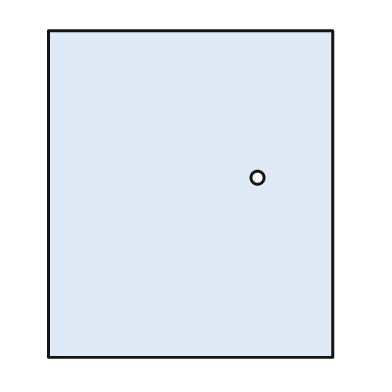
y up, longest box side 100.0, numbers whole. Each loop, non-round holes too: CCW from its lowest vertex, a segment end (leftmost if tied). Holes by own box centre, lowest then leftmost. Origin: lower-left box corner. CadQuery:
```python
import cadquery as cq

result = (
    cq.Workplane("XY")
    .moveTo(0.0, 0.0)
    .lineTo(87.0, 0.0)
    .lineTo(87.0, 100.0)
    .lineTo(0.0, 100.0)
    .close()
    .moveTo(64.0, 55.0)
    .circle(2.0)
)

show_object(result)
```